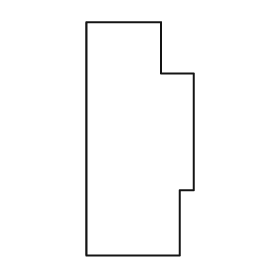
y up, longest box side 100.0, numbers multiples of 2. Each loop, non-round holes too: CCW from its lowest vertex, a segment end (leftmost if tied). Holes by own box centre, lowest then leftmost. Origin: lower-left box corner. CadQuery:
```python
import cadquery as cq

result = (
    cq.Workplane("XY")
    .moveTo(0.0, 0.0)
    .lineTo(40.0, 0.0)
    .lineTo(40.0, 28.0)
    .lineTo(46.0, 28.0)
    .lineTo(46.0, 78.0)
    .lineTo(32.0, 78.0)
    .lineTo(32.0, 100.0)
    .lineTo(0.0, 100.0)
    .close()
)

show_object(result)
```